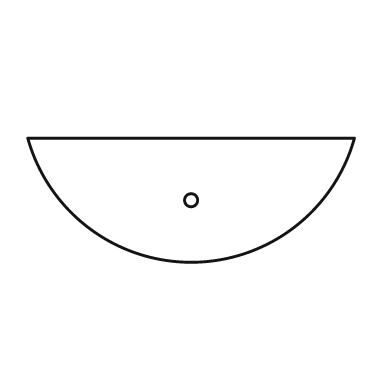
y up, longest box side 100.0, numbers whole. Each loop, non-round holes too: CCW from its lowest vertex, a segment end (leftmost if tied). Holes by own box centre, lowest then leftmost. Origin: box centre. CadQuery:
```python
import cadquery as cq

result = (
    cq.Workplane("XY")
    .moveTo(-50.0, 19.0)
    .threePointArc((0.0, -19.0), (50.0, 19.0))
    .close()
    .moveTo(0.0, 0.0)
    .circle(2.0)
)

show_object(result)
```